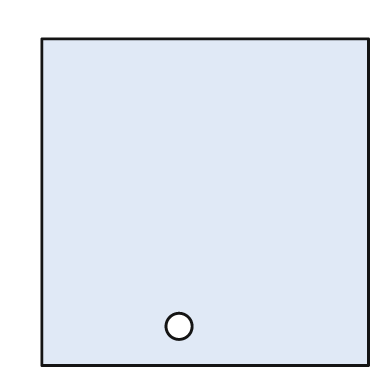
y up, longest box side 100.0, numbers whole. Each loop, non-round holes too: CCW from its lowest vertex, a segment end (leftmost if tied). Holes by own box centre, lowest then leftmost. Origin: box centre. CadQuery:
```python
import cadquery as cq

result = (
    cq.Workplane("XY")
    .moveTo(-50.0, -50.0)
    .lineTo(50.0, -50.0)
    .lineTo(50.0, 50.0)
    .lineTo(-50.0, 50.0)
    .close()
    .moveTo(-8.0, -38.0)
    .circle(4.0)
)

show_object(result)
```